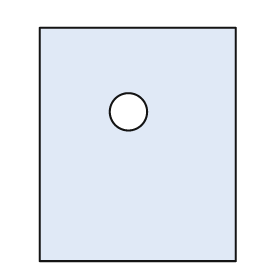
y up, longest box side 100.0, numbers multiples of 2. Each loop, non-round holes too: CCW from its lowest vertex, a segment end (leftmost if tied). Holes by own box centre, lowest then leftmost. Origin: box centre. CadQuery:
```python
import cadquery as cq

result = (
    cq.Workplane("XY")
    .moveTo(-42.0, -50.0)
    .lineTo(42.0, -50.0)
    .lineTo(42.0, 50.0)
    .lineTo(-42.0, 50.0)
    .close()
    .moveTo(-4.0, 14.0)
    .circle(8.0)
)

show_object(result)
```